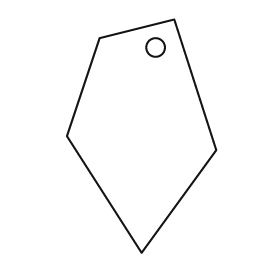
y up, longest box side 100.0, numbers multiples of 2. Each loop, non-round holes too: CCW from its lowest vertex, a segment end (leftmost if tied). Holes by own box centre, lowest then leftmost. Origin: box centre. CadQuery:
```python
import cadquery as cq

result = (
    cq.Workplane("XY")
    .moveTo(0.0, -50.0)
    .lineTo(32.0, -6.0)
    .lineTo(14.0, 50.0)
    .lineTo(-18.0, 42.0)
    .lineTo(-32.0, 0.0)
    .close()
    .moveTo(6.0, 38.0)
    .circle(4.0)
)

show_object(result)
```